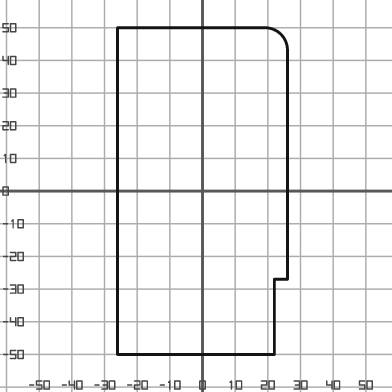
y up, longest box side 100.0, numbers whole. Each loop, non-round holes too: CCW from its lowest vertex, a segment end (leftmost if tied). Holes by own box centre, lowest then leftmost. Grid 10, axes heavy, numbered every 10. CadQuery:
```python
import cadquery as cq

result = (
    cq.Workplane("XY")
    .moveTo(-26.0, -50.0)
    .lineTo(22.0, -50.0)
    .lineTo(22.0, -27.0)
    .lineTo(26.0, -27.0)
    .lineTo(26.0, 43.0)
    .threePointArc((24.0, 48.0), (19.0, 50.0))
    .lineTo(-26.0, 50.0)
    .close()
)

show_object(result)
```